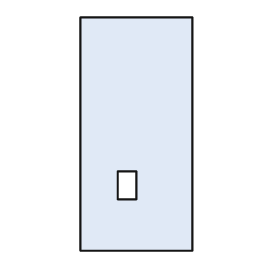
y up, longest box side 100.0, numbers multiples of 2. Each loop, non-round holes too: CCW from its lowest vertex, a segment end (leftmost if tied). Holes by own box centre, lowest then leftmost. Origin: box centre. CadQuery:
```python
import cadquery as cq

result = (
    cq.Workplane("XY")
    .moveTo(-24.0, -50.0)
    .lineTo(24.0, -50.0)
    .lineTo(24.0, 50.0)
    .lineTo(-24.0, 50.0)
    .close()
    .moveTo(-8.0, -28.0)
    .lineTo(0.0, -28.0)
    .lineTo(0.0, -16.0)
    .lineTo(-8.0, -16.0)
    .close()
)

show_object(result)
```